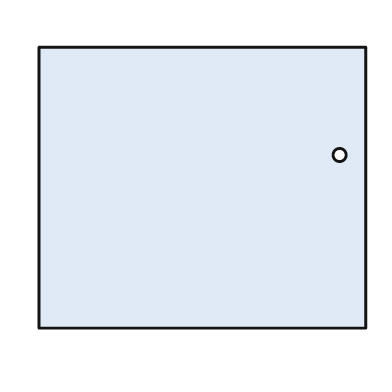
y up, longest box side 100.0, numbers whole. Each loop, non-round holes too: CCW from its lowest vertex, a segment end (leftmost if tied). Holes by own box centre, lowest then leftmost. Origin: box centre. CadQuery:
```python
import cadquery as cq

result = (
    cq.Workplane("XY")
    .moveTo(-50.0, -43.0)
    .lineTo(50.0, -43.0)
    .lineTo(50.0, 43.0)
    .lineTo(-50.0, 43.0)
    .close()
    .moveTo(42.0, 10.0)
    .circle(2.0)
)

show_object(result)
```